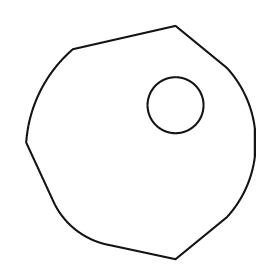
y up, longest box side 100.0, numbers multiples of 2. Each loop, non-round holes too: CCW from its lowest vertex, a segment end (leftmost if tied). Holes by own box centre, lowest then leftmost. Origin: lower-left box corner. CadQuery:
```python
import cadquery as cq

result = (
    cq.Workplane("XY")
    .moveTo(64.0, 0.0)
    .lineTo(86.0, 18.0)
    .threePointArc((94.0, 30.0), (98.0, 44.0))
    .lineTo(98.0, 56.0)
    .threePointArc((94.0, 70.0), (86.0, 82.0))
    .lineTo(64.0, 100.0)
    .lineTo(20.0, 90.0)
    .threePointArc((6.0, 72.0), (0.0, 50.0))
    .lineTo(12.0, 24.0)
    .threePointArc((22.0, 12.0), (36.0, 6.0))
    .close()
    .moveTo(64.0, 66.0)
    .circle(12.0)
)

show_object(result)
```